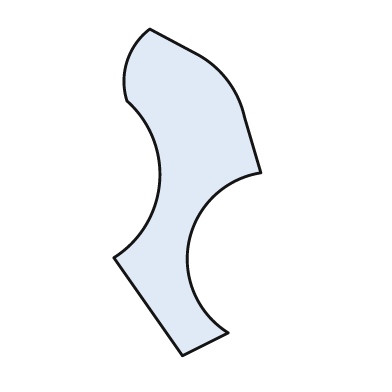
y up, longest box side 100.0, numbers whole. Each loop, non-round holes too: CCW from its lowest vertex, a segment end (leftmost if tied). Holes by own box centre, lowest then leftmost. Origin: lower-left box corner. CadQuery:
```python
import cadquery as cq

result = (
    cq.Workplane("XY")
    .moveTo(21.0, 0.0)
    .lineTo(35.0, 7.0)
    .threePointArc((23.0, 35.0), (45.0, 56.0))
    .lineTo(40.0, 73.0)
    .threePointArc((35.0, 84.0), (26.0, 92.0))
    .lineTo(11.0, 100.0)
    .threePointArc((4.0, 90.0), (4.0, 78.0))
    .threePointArc((14.0, 53.0), (0.0, 30.0))
    .close()
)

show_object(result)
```